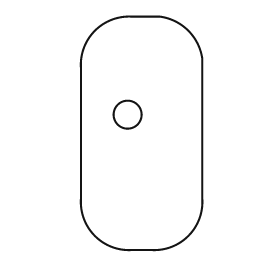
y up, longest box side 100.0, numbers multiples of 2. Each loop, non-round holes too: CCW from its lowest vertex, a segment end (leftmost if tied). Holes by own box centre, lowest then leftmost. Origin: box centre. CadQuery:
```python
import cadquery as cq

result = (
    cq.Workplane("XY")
    .moveTo(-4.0, -50.0)
    .lineTo(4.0, -50.0)
    .threePointArc((20.0, -44.0), (26.0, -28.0))
    .lineTo(26.0, 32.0)
    .threePointArc((20.0, 44.0), (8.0, 50.0))
    .lineTo(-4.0, 50.0)
    .threePointArc((-20.0, 44.0), (-26.0, 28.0))
    .lineTo(-26.0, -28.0)
    .threePointArc((-20.0, -44.0), (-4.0, -50.0))
    .close()
    .moveTo(-6.0, 8.0)
    .circle(6.0)
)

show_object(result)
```